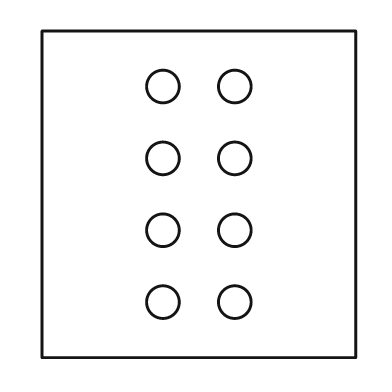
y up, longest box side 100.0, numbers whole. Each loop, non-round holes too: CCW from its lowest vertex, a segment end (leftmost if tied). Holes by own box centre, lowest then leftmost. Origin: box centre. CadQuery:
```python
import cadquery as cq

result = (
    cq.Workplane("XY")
    .moveTo(-48.0, -50.0)
    .lineTo(48.0, -50.0)
    .lineTo(48.0, 50.0)
    .lineTo(-48.0, 50.0)
    .close()
    .moveTo(-11.0, -33.0)
    .circle(5.0)
    .moveTo(11.0, -33.0)
    .circle(5.0)
    .moveTo(-11.0, -11.0)
    .circle(5.0)
    .moveTo(11.0, -11.0)
    .circle(5.0)
    .moveTo(-11.0, 11.0)
    .circle(5.0)
    .moveTo(11.0, 11.0)
    .circle(5.0)
    .moveTo(-11.0, 33.0)
    .circle(5.0)
    .moveTo(11.0, 33.0)
    .circle(5.0)
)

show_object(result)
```